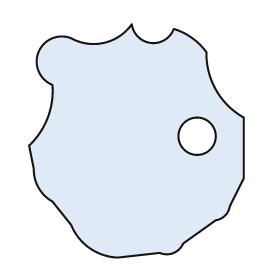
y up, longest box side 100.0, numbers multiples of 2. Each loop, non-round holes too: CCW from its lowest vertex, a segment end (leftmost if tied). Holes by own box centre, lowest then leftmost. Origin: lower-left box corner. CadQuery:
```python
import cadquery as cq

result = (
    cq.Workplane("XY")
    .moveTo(38.0, 0.0)
    .lineTo(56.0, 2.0)
    .threePointArc((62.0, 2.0), (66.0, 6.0))
    .lineTo(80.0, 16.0)
    .threePointArc((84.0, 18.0), (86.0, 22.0))
    .lineTo(92.0, 34.0)
    .lineTo(92.0, 60.0)
    .threePointArc((80.0, 72.0), (76.0, 88.0))
    .threePointArc((70.0, 94.0), (62.0, 98.0))
    .threePointArc((52.0, 92.0), (44.0, 100.0))
    .threePointArc((32.0, 92.0), (18.0, 94.0))
    .threePointArc((4.0, 88.0), (10.0, 74.0))
    .threePointArc((8.0, 60.0), (0.0, 48.0))
    .lineTo(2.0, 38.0)
    .threePointArc((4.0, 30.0), (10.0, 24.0))
    .lineTo(18.0, 14.0)
    .threePointArc((26.0, 4.0), (38.0, 0.0))
    .close()
    .moveTo(72.0, 52.0)
    .circle(8.0)
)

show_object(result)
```